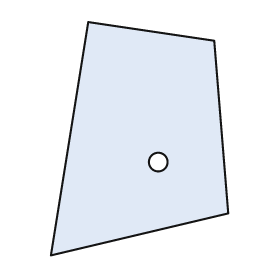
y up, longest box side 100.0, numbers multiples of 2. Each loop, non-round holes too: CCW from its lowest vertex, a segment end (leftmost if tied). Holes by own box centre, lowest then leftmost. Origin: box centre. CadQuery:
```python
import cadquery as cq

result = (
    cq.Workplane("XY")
    .moveTo(-38.0, -50.0)
    .lineTo(38.0, -32.0)
    .lineTo(32.0, 42.0)
    .lineTo(-22.0, 50.0)
    .close()
    .moveTo(8.0, -10.0)
    .circle(4.0)
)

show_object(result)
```